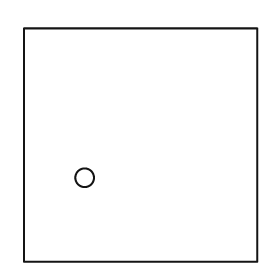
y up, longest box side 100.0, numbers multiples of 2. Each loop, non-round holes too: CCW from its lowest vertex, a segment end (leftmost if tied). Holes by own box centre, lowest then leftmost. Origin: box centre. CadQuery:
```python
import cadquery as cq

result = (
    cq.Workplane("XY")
    .moveTo(-50.0, -50.0)
    .lineTo(50.0, -50.0)
    .lineTo(50.0, 50.0)
    .lineTo(-50.0, 50.0)
    .close()
    .moveTo(-24.0, -14.0)
    .circle(4.0)
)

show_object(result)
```